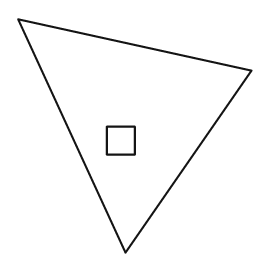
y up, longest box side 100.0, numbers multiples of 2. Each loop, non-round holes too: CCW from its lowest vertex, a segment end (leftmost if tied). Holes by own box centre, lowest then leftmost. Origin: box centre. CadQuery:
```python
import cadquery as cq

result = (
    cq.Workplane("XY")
    .moveTo(-4.0, -50.0)
    .lineTo(50.0, 28.0)
    .lineTo(-50.0, 50.0)
    .close()
    .moveTo(-12.0, -8.0)
    .lineTo(0.0, -8.0)
    .lineTo(0.0, 4.0)
    .lineTo(-12.0, 4.0)
    .close()
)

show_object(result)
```